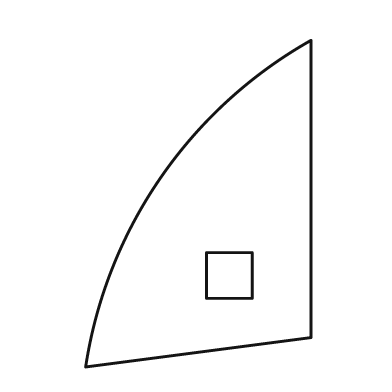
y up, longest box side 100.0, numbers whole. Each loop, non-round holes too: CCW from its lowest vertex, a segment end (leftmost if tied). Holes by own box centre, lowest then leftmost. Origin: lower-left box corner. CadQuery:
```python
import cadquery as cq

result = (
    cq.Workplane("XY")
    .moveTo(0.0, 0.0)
    .lineTo(69.0, 9.0)
    .lineTo(69.0, 100.0)
    .threePointArc((23.0, 58.0), (0.0, 0.0))
    .close()
    .moveTo(37.0, 21.0)
    .lineTo(51.0, 21.0)
    .lineTo(51.0, 35.0)
    .lineTo(37.0, 35.0)
    .close()
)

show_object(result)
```